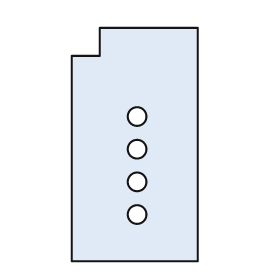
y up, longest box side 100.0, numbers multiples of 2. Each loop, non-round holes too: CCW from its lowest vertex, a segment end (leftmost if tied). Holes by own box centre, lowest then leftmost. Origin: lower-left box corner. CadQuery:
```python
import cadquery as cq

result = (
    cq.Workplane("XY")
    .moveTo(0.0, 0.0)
    .lineTo(54.0, 0.0)
    .lineTo(54.0, 100.0)
    .lineTo(12.0, 100.0)
    .lineTo(12.0, 88.0)
    .lineTo(0.0, 88.0)
    .close()
    .moveTo(28.0, 20.0)
    .circle(4.0)
    .moveTo(28.0, 34.0)
    .circle(4.0)
    .moveTo(28.0, 48.0)
    .circle(4.0)
    .moveTo(28.0, 62.0)
    .circle(4.0)
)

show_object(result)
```